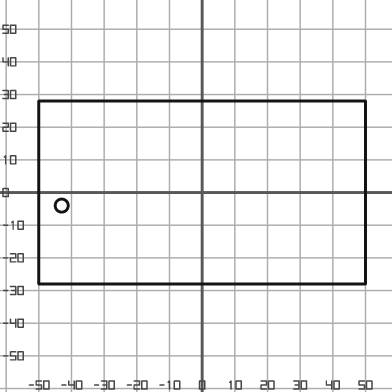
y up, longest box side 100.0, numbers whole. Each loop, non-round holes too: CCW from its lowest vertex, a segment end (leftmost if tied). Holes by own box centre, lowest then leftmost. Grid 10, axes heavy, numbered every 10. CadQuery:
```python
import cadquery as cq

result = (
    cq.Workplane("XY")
    .moveTo(-50.0, -28.0)
    .lineTo(50.0, -28.0)
    .lineTo(50.0, 28.0)
    .lineTo(-50.0, 28.0)
    .close()
    .moveTo(-43.0, -4.0)
    .circle(2.0)
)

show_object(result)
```